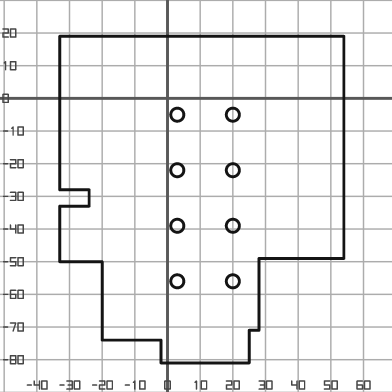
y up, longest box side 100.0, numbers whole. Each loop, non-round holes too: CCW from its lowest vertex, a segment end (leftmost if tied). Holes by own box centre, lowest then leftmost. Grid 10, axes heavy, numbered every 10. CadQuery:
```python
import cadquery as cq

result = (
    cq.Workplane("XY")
    .moveTo(-2.0, -81.0)
    .lineTo(25.0, -81.0)
    .lineTo(25.0, -71.0)
    .lineTo(28.0, -71.0)
    .lineTo(28.0, -49.0)
    .lineTo(54.0, -49.0)
    .lineTo(54.0, 19.0)
    .lineTo(-33.0, 19.0)
    .lineTo(-33.0, -28.0)
    .lineTo(-24.0, -28.0)
    .lineTo(-24.0, -33.0)
    .lineTo(-33.0, -33.0)
    .lineTo(-33.0, -50.0)
    .lineTo(-20.0, -50.0)
    .lineTo(-20.0, -74.0)
    .lineTo(-2.0, -74.0)
    .close()
    .moveTo(3.0, -56.0)
    .circle(2.0)
    .moveTo(20.0, -56.0)
    .circle(2.0)
    .moveTo(3.0, -39.0)
    .circle(2.0)
    .moveTo(20.0, -39.0)
    .circle(2.0)
    .moveTo(3.0, -22.0)
    .circle(2.0)
    .moveTo(20.0, -22.0)
    .circle(2.0)
    .moveTo(3.0, -5.0)
    .circle(2.0)
    .moveTo(20.0, -5.0)
    .circle(2.0)
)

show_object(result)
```